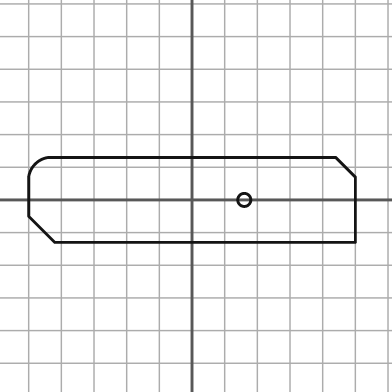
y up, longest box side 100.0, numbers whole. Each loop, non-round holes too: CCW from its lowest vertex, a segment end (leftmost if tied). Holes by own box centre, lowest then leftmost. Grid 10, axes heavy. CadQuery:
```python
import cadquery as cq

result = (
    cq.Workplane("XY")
    .moveTo(-42.0, -13.0)
    .lineTo(50.0, -13.0)
    .lineTo(50.0, 7.0)
    .lineTo(44.0, 13.0)
    .lineTo(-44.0, 13.0)
    .threePointArc((-48.0, 11.0), (-50.0, 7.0))
    .lineTo(-50.0, -5.0)
    .close()
    .moveTo(16.0, 0.0)
    .circle(2.0)
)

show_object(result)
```